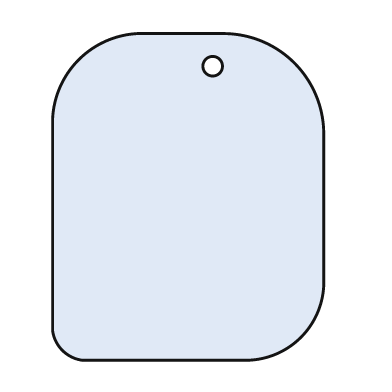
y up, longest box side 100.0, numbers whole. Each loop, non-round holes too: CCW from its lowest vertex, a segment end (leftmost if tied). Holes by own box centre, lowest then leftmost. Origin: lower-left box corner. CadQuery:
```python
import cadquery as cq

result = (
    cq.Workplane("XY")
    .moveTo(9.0, 0.0)
    .lineTo(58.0, 0.0)
    .threePointArc((76.0, 7.0), (83.0, 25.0))
    .lineTo(83.0, 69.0)
    .threePointArc((74.0, 91.0), (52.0, 100.0))
    .lineTo(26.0, 100.0)
    .threePointArc((8.0, 92.0), (0.0, 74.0))
    .lineTo(0.0, 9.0)
    .threePointArc((3.0, 3.0), (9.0, 0.0))
    .close()
    .moveTo(49.0, 90.0)
    .circle(3.0)
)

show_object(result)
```